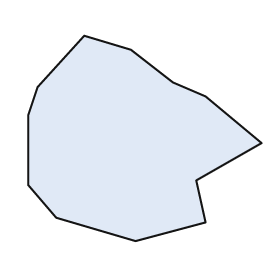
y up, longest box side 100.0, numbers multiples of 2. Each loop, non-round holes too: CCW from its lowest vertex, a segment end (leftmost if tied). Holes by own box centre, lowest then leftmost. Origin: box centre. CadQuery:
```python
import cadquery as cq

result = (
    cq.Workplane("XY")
    .moveTo(-4.0, -44.0)
    .lineTo(26.0, -36.0)
    .lineTo(22.0, -18.0)
    .lineTo(50.0, -2.0)
    .lineTo(26.0, 18.0)
    .lineTo(12.0, 24.0)
    .lineTo(-6.0, 38.0)
    .lineTo(-26.0, 44.0)
    .lineTo(-46.0, 22.0)
    .lineTo(-50.0, 10.0)
    .lineTo(-50.0, -20.0)
    .lineTo(-38.0, -34.0)
    .close()
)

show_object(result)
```